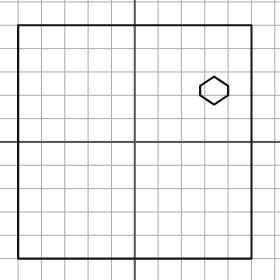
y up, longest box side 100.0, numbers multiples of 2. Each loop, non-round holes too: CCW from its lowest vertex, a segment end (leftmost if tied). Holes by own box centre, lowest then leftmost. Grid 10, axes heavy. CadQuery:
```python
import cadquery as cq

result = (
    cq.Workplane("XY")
    .moveTo(-50.0, -50.0)
    .lineTo(50.0, -50.0)
    .lineTo(50.0, 50.0)
    .lineTo(-50.0, 50.0)
    .close()
    .moveTo(34.0, 16.0)
    .lineTo(40.0, 20.0)
    .lineTo(40.0, 24.0)
    .lineTo(34.0, 28.0)
    .lineTo(28.0, 24.0)
    .lineTo(28.0, 20.0)
    .close()
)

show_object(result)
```